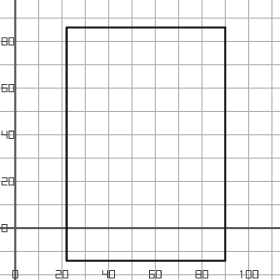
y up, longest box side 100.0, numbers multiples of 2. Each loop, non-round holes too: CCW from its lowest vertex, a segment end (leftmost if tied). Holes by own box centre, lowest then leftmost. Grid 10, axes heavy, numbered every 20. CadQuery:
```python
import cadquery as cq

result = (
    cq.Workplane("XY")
    .moveTo(22.0, -14.0)
    .lineTo(90.0, -14.0)
    .lineTo(90.0, 86.0)
    .lineTo(22.0, 86.0)
    .close()
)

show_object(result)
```